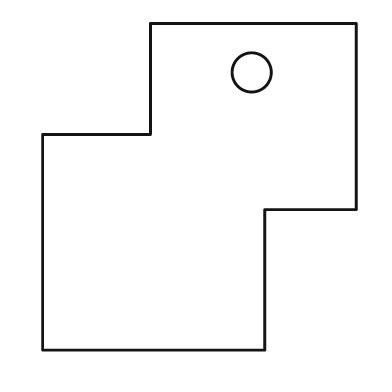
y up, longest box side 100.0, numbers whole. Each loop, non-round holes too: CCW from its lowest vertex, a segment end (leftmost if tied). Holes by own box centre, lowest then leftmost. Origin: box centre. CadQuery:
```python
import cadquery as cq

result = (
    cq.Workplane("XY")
    .moveTo(-48.0, -50.0)
    .lineTo(20.0, -50.0)
    .lineTo(20.0, -7.0)
    .lineTo(48.0, -7.0)
    .lineTo(48.0, 50.0)
    .lineTo(-15.0, 50.0)
    .lineTo(-15.0, 16.0)
    .lineTo(-48.0, 16.0)
    .close()
    .moveTo(16.0, 35.0)
    .circle(6.0)
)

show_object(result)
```